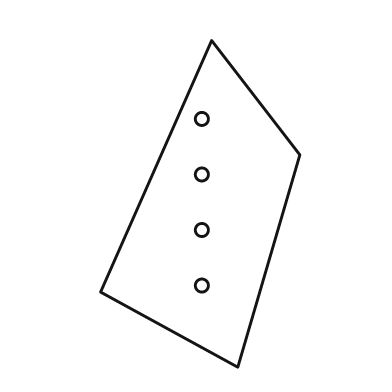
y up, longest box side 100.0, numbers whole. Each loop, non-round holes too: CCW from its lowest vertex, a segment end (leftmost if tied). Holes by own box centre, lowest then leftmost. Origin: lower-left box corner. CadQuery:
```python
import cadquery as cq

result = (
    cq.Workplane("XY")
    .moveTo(42.0, 0.0)
    .lineTo(61.0, 65.0)
    .lineTo(34.0, 100.0)
    .lineTo(0.0, 23.0)
    .close()
    .moveTo(31.0, 25.0)
    .circle(2.0)
    .moveTo(31.0, 42.0)
    .circle(2.0)
    .moveTo(31.0, 59.0)
    .circle(2.0)
    .moveTo(31.0, 76.0)
    .circle(2.0)
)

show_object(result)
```